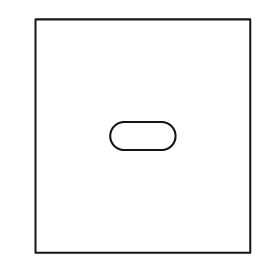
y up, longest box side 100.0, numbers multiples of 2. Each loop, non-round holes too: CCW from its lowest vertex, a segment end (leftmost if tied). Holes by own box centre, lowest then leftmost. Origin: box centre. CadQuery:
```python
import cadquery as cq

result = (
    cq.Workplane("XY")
    .moveTo(-46.0, -50.0)
    .lineTo(46.0, -50.0)
    .lineTo(46.0, 50.0)
    .lineTo(-46.0, 50.0)
    .close()
    .moveTo(-8.0, -6.0)
    .lineTo(8.0, -6.0)
    .threePointArc((14.0, 0.0), (8.0, 6.0))
    .lineTo(-8.0, 6.0)
    .threePointArc((-14.0, 0.0), (-8.0, -6.0))
    .close()
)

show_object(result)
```